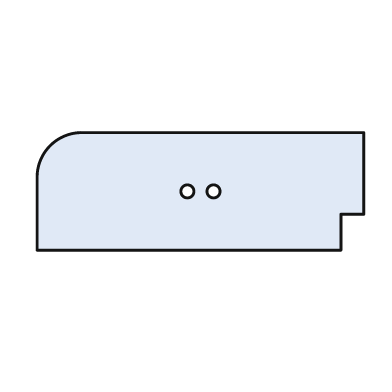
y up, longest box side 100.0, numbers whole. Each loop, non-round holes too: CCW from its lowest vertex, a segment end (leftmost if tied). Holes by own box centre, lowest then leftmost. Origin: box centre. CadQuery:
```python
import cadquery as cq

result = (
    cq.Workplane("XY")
    .moveTo(-50.0, -18.0)
    .lineTo(43.0, -18.0)
    .lineTo(43.0, -7.0)
    .lineTo(50.0, -7.0)
    .lineTo(50.0, 18.0)
    .lineTo(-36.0, 18.0)
    .threePointArc((-46.0, 14.0), (-50.0, 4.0))
    .close()
    .moveTo(-4.0, 0.0)
    .circle(2.0)
    .moveTo(4.0, 0.0)
    .circle(2.0)
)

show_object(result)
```